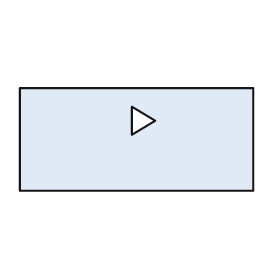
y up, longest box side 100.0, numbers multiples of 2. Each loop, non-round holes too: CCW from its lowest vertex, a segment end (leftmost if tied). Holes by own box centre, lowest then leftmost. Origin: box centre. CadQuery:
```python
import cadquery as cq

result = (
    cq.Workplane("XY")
    .moveTo(-50.0, -22.0)
    .lineTo(50.0, -22.0)
    .lineTo(50.0, 22.0)
    .lineTo(-50.0, 22.0)
    .close()
    .moveTo(-2.0, 2.0)
    .lineTo(8.0, 8.0)
    .lineTo(-2.0, 14.0)
    .close()
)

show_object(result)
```